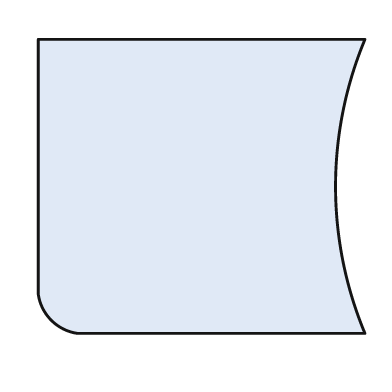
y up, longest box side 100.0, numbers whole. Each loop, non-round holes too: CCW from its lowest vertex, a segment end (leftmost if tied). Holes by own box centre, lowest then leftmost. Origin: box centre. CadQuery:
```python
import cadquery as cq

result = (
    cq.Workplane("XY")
    .moveTo(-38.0, -45.0)
    .lineTo(50.0, -45.0)
    .threePointArc((41.0, 0.0), (50.0, 45.0))
    .lineTo(-50.0, 45.0)
    .lineTo(-50.0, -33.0)
    .threePointArc((-46.0, -41.0), (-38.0, -45.0))
    .close()
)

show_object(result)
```